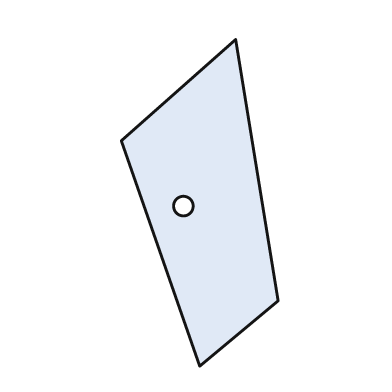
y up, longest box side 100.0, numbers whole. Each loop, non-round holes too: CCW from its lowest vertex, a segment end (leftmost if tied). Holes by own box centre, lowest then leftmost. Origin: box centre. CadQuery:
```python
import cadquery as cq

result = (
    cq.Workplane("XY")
    .moveTo(0.0, -50.0)
    .lineTo(24.0, -30.0)
    .lineTo(11.0, 50.0)
    .lineTo(-24.0, 19.0)
    .close()
    .moveTo(-5.0, -1.0)
    .circle(3.0)
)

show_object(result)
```